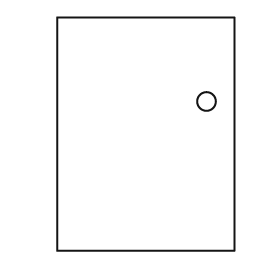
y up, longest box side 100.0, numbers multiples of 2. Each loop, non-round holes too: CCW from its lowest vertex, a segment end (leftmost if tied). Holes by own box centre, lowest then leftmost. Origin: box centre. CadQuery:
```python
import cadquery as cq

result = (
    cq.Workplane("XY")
    .moveTo(-38.0, -50.0)
    .lineTo(38.0, -50.0)
    .lineTo(38.0, 50.0)
    .lineTo(-38.0, 50.0)
    .close()
    .moveTo(26.0, 14.0)
    .circle(4.0)
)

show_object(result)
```